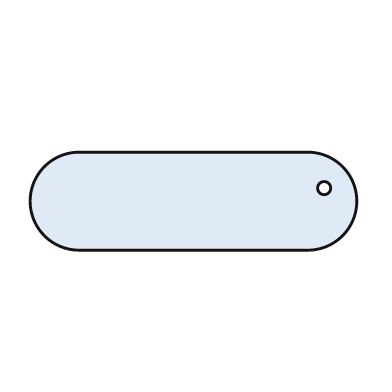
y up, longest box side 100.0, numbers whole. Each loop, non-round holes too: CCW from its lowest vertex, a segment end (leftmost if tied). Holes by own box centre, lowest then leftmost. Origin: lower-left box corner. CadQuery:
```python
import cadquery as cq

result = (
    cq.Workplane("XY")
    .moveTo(15.0, 0.0)
    .lineTo(85.0, 0.0)
    .threePointArc((100.0, 15.0), (85.0, 30.0))
    .lineTo(15.0, 30.0)
    .threePointArc((0.0, 15.0), (15.0, 0.0))
    .close()
    .moveTo(90.0, 19.0)
    .circle(2.0)
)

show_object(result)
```